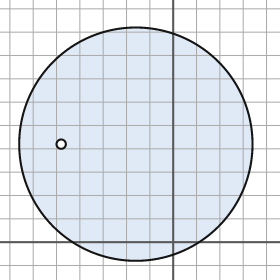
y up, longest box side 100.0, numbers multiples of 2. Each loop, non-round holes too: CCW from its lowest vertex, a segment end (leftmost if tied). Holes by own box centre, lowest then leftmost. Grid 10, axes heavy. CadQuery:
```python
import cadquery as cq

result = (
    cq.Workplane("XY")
    .moveTo(-16.0, 42.0)
    .circle(50.0)
    .moveTo(-48.0, 42.0)
    .circle(2.0)
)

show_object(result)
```